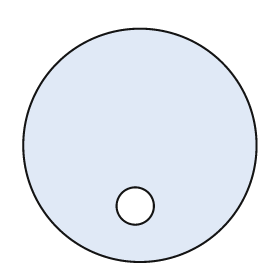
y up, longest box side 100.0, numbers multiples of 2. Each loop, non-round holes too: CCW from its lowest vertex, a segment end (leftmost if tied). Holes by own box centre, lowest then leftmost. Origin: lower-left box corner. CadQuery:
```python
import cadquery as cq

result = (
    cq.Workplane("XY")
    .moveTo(50.0, 50.0)
    .circle(50.0)
    .moveTo(48.0, 24.0)
    .circle(8.0)
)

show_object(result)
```